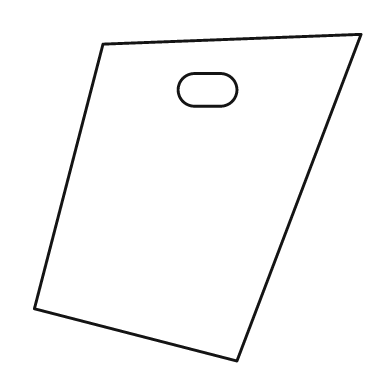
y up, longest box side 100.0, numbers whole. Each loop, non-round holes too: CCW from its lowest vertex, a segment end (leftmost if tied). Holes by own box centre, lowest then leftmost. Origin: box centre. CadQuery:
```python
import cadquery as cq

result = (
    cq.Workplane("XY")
    .moveTo(12.0, -50.0)
    .lineTo(50.0, 50.0)
    .lineTo(-29.0, 47.0)
    .lineTo(-50.0, -34.0)
    .close()
    .moveTo(-1.0, 28.0)
    .lineTo(7.0, 28.0)
    .threePointArc((12.0, 33.0), (7.0, 38.0))
    .lineTo(-1.0, 38.0)
    .threePointArc((-6.0, 33.0), (-1.0, 28.0))
    .close()
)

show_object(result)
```